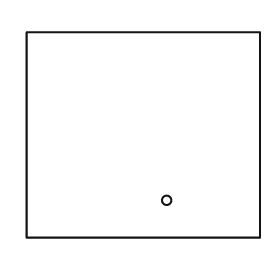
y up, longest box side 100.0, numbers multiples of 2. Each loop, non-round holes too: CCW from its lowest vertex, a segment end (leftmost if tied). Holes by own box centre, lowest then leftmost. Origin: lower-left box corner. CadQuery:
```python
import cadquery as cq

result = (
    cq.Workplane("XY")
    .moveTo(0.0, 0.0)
    .lineTo(100.0, 0.0)
    .lineTo(100.0, 88.0)
    .lineTo(0.0, 88.0)
    .close()
    .moveTo(60.0, 16.0)
    .circle(2.0)
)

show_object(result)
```